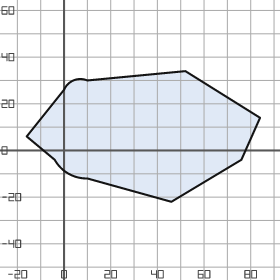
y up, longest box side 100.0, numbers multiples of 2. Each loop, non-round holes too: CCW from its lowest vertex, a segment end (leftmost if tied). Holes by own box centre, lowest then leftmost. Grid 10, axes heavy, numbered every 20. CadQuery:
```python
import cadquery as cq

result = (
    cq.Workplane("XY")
    .moveTo(46.0, -22.0)
    .lineTo(76.0, -4.0)
    .lineTo(84.0, 14.0)
    .lineTo(52.0, 34.0)
    .lineTo(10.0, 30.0)
    .threePointArc((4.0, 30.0), (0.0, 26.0))
    .lineTo(-16.0, 6.0)
    .lineTo(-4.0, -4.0)
    .threePointArc((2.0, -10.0), (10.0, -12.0))
    .close()
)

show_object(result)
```